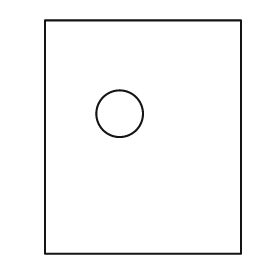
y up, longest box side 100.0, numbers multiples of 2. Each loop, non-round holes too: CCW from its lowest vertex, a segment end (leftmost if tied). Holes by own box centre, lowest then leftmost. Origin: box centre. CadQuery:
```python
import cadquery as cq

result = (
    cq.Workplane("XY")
    .moveTo(-42.0, -50.0)
    .lineTo(42.0, -50.0)
    .lineTo(42.0, 50.0)
    .lineTo(-42.0, 50.0)
    .close()
    .moveTo(-10.0, 10.0)
    .circle(10.0)
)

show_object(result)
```